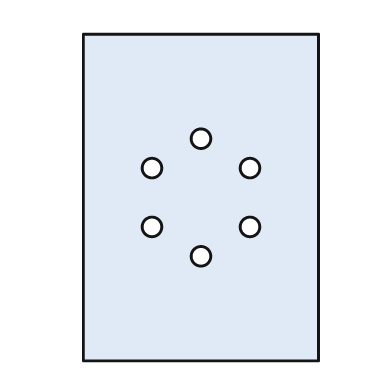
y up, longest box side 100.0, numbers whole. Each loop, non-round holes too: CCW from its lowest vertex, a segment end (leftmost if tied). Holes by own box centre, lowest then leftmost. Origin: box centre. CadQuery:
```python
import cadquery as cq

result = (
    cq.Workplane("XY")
    .moveTo(-36.0, -50.0)
    .lineTo(36.0, -50.0)
    .lineTo(36.0, 50.0)
    .lineTo(-36.0, 50.0)
    .close()
    .moveTo(0.0, -18.0)
    .circle(3.0)
    .moveTo(-15.0, -9.0)
    .circle(3.0)
    .moveTo(15.0, -9.0)
    .circle(3.0)
    .moveTo(-15.0, 9.0)
    .circle(3.0)
    .moveTo(15.0, 9.0)
    .circle(3.0)
    .moveTo(0.0, 18.0)
    .circle(3.0)
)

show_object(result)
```